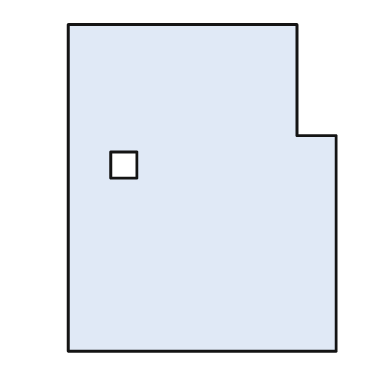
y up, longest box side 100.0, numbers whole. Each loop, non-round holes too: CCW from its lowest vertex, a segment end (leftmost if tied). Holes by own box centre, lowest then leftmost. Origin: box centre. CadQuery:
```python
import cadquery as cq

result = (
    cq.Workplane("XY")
    .moveTo(-41.0, -50.0)
    .lineTo(41.0, -50.0)
    .lineTo(41.0, 16.0)
    .lineTo(29.0, 16.0)
    .lineTo(29.0, 50.0)
    .lineTo(-41.0, 50.0)
    .close()
    .moveTo(-28.0, 3.0)
    .lineTo(-20.0, 3.0)
    .lineTo(-20.0, 11.0)
    .lineTo(-28.0, 11.0)
    .close()
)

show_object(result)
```